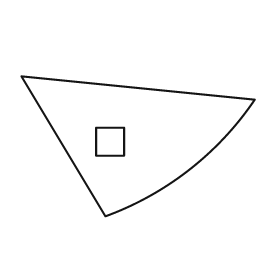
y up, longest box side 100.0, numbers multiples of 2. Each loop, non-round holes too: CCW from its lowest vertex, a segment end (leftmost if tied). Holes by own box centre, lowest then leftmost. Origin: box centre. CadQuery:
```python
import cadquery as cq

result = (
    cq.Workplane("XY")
    .moveTo(-14.0, -30.0)
    .threePointArc((22.0, -10.0), (50.0, 20.0))
    .lineTo(-50.0, 30.0)
    .close()
    .moveTo(-18.0, -4.0)
    .lineTo(-6.0, -4.0)
    .lineTo(-6.0, 8.0)
    .lineTo(-18.0, 8.0)
    .close()
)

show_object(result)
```